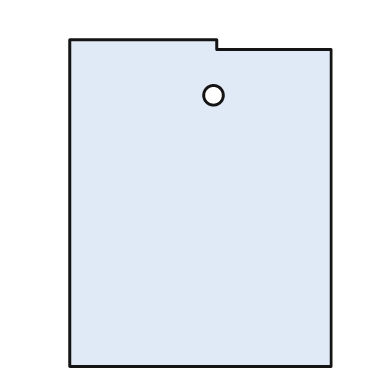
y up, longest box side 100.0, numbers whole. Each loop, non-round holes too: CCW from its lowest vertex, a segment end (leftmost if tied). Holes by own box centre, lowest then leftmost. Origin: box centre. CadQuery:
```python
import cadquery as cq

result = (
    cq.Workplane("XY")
    .moveTo(-40.0, -50.0)
    .lineTo(40.0, -50.0)
    .lineTo(40.0, 47.0)
    .lineTo(5.0, 47.0)
    .lineTo(5.0, 50.0)
    .lineTo(-40.0, 50.0)
    .close()
    .moveTo(4.0, 33.0)
    .circle(3.0)
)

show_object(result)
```